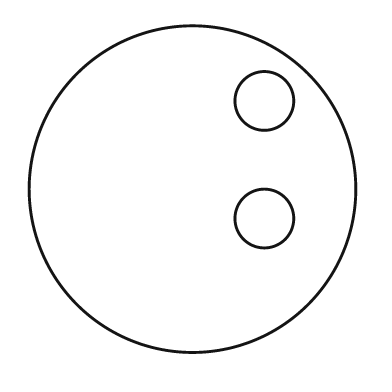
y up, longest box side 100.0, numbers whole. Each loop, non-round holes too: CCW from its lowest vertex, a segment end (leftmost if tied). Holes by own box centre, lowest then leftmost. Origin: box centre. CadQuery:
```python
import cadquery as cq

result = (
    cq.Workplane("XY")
    .moveTo(0.0, 0.0)
    .circle(50.0)
    .moveTo(22.0, -9.0)
    .circle(9.0)
    .moveTo(22.0, 27.0)
    .circle(9.0)
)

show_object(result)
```